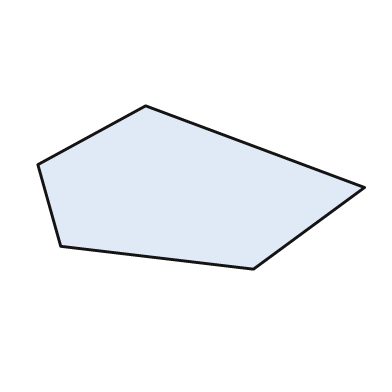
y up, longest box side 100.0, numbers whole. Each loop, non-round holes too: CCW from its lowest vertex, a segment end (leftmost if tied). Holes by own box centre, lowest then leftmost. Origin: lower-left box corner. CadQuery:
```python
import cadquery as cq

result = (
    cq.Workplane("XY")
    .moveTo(66.0, 0.0)
    .lineTo(100.0, 25.0)
    .lineTo(33.0, 50.0)
    .lineTo(0.0, 32.0)
    .lineTo(7.0, 7.0)
    .close()
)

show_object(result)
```